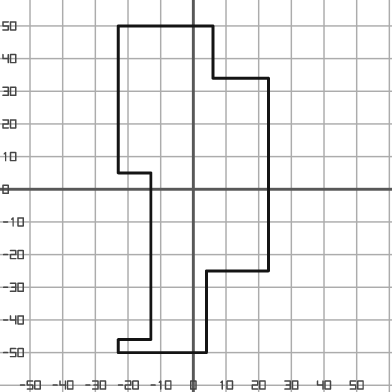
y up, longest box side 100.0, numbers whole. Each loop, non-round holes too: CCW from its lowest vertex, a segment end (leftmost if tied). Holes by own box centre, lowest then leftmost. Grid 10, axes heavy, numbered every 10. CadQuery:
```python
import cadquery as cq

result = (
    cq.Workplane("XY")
    .moveTo(-23.0, -50.0)
    .lineTo(4.0, -50.0)
    .lineTo(4.0, -25.0)
    .lineTo(23.0, -25.0)
    .lineTo(23.0, 34.0)
    .lineTo(6.0, 34.0)
    .lineTo(6.0, 50.0)
    .lineTo(-23.0, 50.0)
    .lineTo(-23.0, 5.0)
    .lineTo(-13.0, 5.0)
    .lineTo(-13.0, -46.0)
    .lineTo(-23.0, -46.0)
    .close()
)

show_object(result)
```